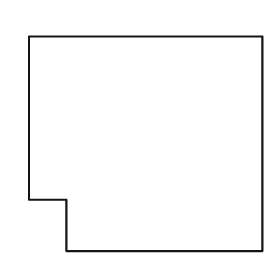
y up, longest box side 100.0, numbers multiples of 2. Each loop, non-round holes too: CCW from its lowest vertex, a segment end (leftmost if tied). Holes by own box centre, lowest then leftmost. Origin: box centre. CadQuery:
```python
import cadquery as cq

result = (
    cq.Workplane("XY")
    .moveTo(-34.0, -46.0)
    .lineTo(50.0, -46.0)
    .lineTo(50.0, 46.0)
    .lineTo(-50.0, 46.0)
    .lineTo(-50.0, -24.0)
    .lineTo(-34.0, -24.0)
    .close()
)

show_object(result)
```